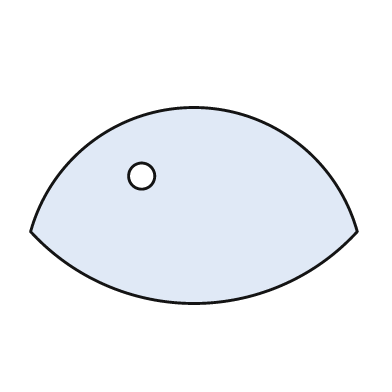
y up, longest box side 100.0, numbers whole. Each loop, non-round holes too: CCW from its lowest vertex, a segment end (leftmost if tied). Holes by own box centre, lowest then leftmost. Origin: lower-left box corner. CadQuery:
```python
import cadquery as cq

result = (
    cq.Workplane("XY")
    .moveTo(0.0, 22.0)
    .threePointArc((50.0, 0.0), (100.0, 22.0))
    .threePointArc((50.0, 60.0), (0.0, 22.0))
    .close()
    .moveTo(34.0, 39.0)
    .circle(4.0)
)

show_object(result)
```